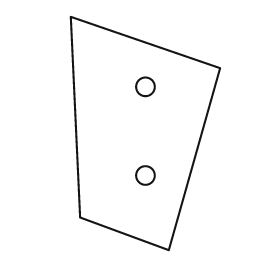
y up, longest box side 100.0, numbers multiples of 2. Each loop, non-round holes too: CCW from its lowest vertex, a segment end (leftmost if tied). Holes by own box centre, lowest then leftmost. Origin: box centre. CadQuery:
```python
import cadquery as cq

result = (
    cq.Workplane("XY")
    .moveTo(10.0, -50.0)
    .lineTo(32.0, 28.0)
    .lineTo(-32.0, 50.0)
    .lineTo(-28.0, -36.0)
    .close()
    .moveTo(0.0, -18.0)
    .circle(4.0)
    .moveTo(0.0, 20.0)
    .circle(4.0)
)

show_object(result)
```